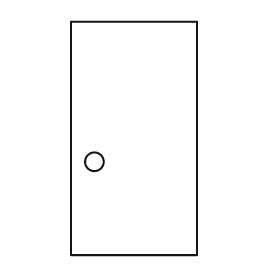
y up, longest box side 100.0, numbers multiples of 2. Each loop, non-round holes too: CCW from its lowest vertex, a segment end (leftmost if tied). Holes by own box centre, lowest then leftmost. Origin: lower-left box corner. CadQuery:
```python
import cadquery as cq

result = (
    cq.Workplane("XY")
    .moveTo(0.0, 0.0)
    .lineTo(54.0, 0.0)
    .lineTo(54.0, 100.0)
    .lineTo(0.0, 100.0)
    .close()
    .moveTo(10.0, 40.0)
    .circle(4.0)
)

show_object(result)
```